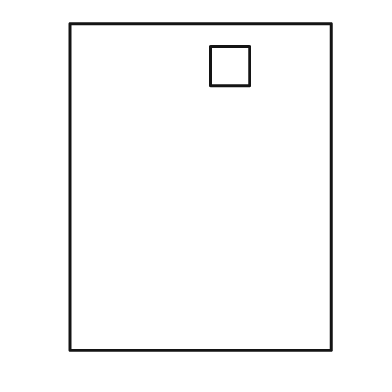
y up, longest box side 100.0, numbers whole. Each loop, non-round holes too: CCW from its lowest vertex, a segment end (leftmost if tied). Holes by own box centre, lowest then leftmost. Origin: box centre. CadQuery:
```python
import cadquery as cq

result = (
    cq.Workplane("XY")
    .moveTo(-40.0, -50.0)
    .lineTo(40.0, -50.0)
    .lineTo(40.0, 50.0)
    .lineTo(-40.0, 50.0)
    .close()
    .moveTo(3.0, 31.0)
    .lineTo(15.0, 31.0)
    .lineTo(15.0, 43.0)
    .lineTo(3.0, 43.0)
    .close()
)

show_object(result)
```